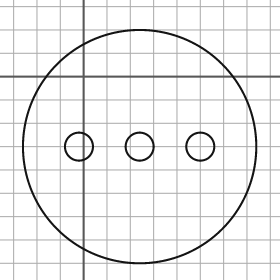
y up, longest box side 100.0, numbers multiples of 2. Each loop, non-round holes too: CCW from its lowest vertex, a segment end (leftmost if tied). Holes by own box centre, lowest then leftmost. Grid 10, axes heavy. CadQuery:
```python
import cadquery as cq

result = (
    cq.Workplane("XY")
    .moveTo(24.0, -30.0)
    .circle(50.0)
    .moveTo(-2.0, -30.0)
    .circle(6.0)
    .moveTo(24.0, -30.0)
    .circle(6.0)
    .moveTo(50.0, -30.0)
    .circle(6.0)
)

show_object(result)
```